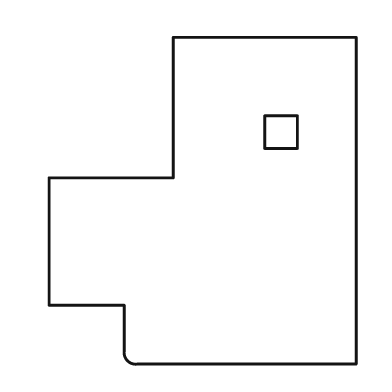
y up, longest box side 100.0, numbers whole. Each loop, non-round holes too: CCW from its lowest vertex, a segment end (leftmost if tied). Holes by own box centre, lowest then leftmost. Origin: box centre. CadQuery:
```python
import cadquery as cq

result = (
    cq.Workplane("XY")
    .moveTo(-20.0, -50.0)
    .lineTo(47.0, -50.0)
    .lineTo(47.0, 50.0)
    .lineTo(-9.0, 50.0)
    .lineTo(-9.0, 7.0)
    .lineTo(-47.0, 7.0)
    .lineTo(-47.0, -32.0)
    .lineTo(-24.0, -32.0)
    .lineTo(-24.0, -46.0)
    .threePointArc((-23.0, -49.0), (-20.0, -50.0))
    .close()
    .moveTo(19.0, 16.0)
    .lineTo(29.0, 16.0)
    .lineTo(29.0, 26.0)
    .lineTo(19.0, 26.0)
    .close()
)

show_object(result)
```